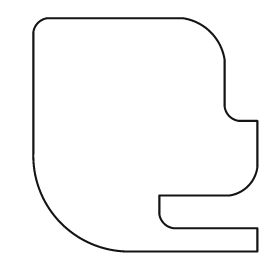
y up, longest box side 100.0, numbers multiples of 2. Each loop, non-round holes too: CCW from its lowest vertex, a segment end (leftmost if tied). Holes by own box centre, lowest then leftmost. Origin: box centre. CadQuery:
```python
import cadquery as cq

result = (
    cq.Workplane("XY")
    .moveTo(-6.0, -50.0)
    .lineTo(48.0, -50.0)
    .lineTo(48.0, -40.0)
    .lineTo(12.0, -40.0)
    .threePointArc((8.0, -38.0), (6.0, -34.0))
    .lineTo(6.0, -26.0)
    .lineTo(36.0, -26.0)
    .threePointArc((44.0, -22.0), (48.0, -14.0))
    .lineTo(48.0, 6.0)
    .lineTo(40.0, 6.0)
    .threePointArc((36.0, 8.0), (34.0, 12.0))
    .lineTo(34.0, 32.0)
    .threePointArc((28.0, 44.0), (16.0, 50.0))
    .lineTo(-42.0, 50.0)
    .threePointArc((-46.0, 48.0), (-48.0, 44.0))
    .lineTo(-48.0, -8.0)
    .threePointArc((-36.0, -38.0), (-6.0, -50.0))
    .close()
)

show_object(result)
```